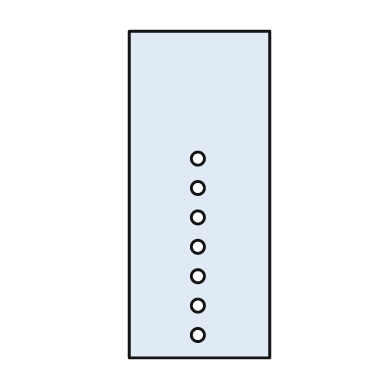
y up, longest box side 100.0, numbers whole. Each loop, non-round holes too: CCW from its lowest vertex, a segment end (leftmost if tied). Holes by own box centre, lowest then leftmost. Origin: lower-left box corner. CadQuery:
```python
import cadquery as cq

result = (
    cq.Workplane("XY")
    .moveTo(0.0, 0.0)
    .lineTo(43.0, 0.0)
    .lineTo(43.0, 100.0)
    .lineTo(0.0, 100.0)
    .close()
    .moveTo(21.0, 7.0)
    .circle(2.0)
    .moveTo(21.0, 16.0)
    .circle(2.0)
    .moveTo(21.0, 25.0)
    .circle(2.0)
    .moveTo(21.0, 34.0)
    .circle(2.0)
    .moveTo(21.0, 43.0)
    .circle(2.0)
    .moveTo(21.0, 52.0)
    .circle(2.0)
    .moveTo(21.0, 61.0)
    .circle(2.0)
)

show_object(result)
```